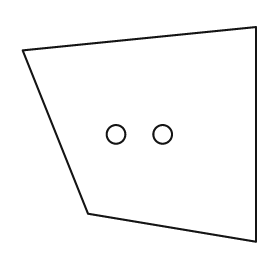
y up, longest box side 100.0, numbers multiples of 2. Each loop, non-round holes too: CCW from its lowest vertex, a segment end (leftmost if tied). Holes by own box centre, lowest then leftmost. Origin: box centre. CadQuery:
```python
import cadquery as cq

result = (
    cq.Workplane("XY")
    .moveTo(50.0, -46.0)
    .lineTo(50.0, 46.0)
    .lineTo(-50.0, 36.0)
    .lineTo(-22.0, -34.0)
    .close()
    .moveTo(-10.0, 0.0)
    .circle(4.0)
    .moveTo(10.0, 0.0)
    .circle(4.0)
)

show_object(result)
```